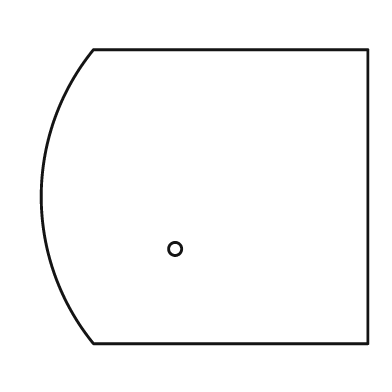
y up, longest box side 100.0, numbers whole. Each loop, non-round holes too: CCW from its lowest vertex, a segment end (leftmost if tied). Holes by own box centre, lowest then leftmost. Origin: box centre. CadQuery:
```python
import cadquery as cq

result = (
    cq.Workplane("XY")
    .moveTo(-34.0, -45.0)
    .lineTo(50.0, -45.0)
    .lineTo(50.0, 45.0)
    .lineTo(-34.0, 45.0)
    .threePointArc((-50.0, 0.0), (-34.0, -45.0))
    .close()
    .moveTo(-9.0, -16.0)
    .circle(2.0)
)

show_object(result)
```